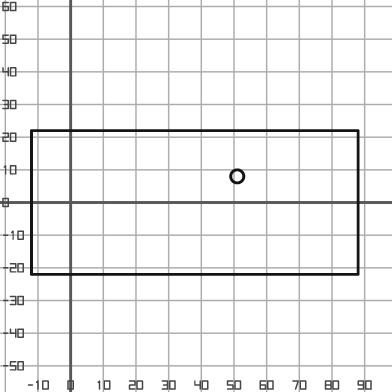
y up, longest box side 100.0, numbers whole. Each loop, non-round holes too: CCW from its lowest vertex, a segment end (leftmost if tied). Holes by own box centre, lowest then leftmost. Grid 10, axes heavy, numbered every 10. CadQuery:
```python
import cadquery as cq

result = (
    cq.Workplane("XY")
    .moveTo(-12.0, -22.0)
    .lineTo(88.0, -22.0)
    .lineTo(88.0, 22.0)
    .lineTo(-12.0, 22.0)
    .close()
    .moveTo(51.0, 8.0)
    .circle(2.0)
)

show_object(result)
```